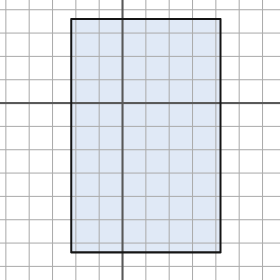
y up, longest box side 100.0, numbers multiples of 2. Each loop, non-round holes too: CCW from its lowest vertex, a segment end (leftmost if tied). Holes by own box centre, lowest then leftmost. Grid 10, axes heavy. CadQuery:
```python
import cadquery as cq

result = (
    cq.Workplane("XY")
    .moveTo(-22.0, -64.0)
    .lineTo(42.0, -64.0)
    .lineTo(42.0, 36.0)
    .lineTo(-22.0, 36.0)
    .close()
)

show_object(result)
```